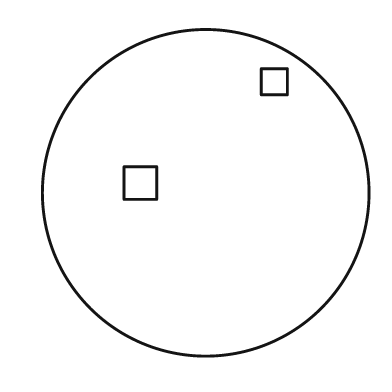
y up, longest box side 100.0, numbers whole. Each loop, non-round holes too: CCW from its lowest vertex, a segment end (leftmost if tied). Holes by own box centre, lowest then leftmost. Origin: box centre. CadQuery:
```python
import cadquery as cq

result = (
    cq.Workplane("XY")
    .moveTo(0.0, 0.0)
    .circle(50.0)
    .moveTo(-25.0, -2.0)
    .lineTo(-15.0, -2.0)
    .lineTo(-15.0, 8.0)
    .lineTo(-25.0, 8.0)
    .close()
    .moveTo(17.0, 30.0)
    .lineTo(25.0, 30.0)
    .lineTo(25.0, 38.0)
    .lineTo(17.0, 38.0)
    .close()
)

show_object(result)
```